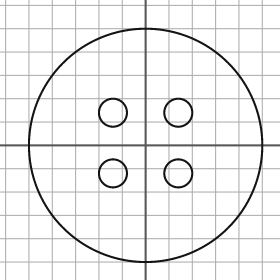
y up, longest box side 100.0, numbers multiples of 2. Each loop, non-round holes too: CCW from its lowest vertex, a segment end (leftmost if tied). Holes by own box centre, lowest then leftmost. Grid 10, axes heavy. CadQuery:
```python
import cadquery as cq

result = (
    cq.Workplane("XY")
    .moveTo(0.0, 0.0)
    .circle(50.0)
    .moveTo(-14.0, -12.0)
    .circle(6.0)
    .moveTo(14.0, -12.0)
    .circle(6.0)
    .moveTo(-14.0, 14.0)
    .circle(6.0)
    .moveTo(14.0, 14.0)
    .circle(6.0)
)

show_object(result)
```